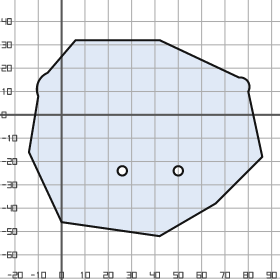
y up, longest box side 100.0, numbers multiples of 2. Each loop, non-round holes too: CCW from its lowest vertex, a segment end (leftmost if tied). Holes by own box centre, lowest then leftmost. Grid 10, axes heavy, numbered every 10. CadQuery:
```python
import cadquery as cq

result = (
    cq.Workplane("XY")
    .moveTo(42.0, -52.0)
    .lineTo(66.0, -38.0)
    .lineTo(86.0, -18.0)
    .lineTo(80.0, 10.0)
    .threePointArc((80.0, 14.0), (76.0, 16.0))
    .lineTo(42.0, 32.0)
    .lineTo(6.0, 32.0)
    .lineTo(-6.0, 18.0)
    .threePointArc((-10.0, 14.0), (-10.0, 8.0))
    .lineTo(-14.0, -16.0)
    .lineTo(0.0, -46.0)
    .close()
    .moveTo(26.0, -24.0)
    .circle(2.0)
    .moveTo(50.0, -24.0)
    .circle(2.0)
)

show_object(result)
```